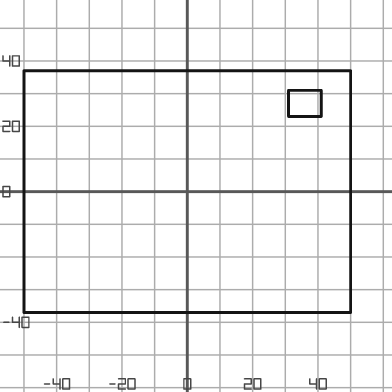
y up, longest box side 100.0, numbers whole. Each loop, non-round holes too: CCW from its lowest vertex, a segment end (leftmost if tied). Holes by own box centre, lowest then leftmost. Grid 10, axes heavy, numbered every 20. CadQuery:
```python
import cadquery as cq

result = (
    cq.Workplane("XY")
    .moveTo(-50.0, -37.0)
    .lineTo(50.0, -37.0)
    .lineTo(50.0, 37.0)
    .lineTo(-50.0, 37.0)
    .close()
    .moveTo(31.0, 23.0)
    .lineTo(41.0, 23.0)
    .lineTo(41.0, 31.0)
    .lineTo(31.0, 31.0)
    .close()
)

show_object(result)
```